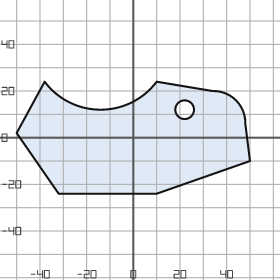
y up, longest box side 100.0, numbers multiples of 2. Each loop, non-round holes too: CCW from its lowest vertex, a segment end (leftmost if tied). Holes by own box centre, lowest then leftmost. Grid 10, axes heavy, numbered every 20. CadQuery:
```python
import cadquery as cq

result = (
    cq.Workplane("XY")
    .moveTo(-32.0, -24.0)
    .lineTo(10.0, -24.0)
    .lineTo(50.0, -10.0)
    .lineTo(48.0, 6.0)
    .threePointArc((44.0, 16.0), (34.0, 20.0))
    .lineTo(10.0, 24.0)
    .threePointArc((-14.0, 12.0), (-38.0, 24.0))
    .lineTo(-50.0, 2.0)
    .close()
    .moveTo(22.0, 12.0)
    .circle(4.0)
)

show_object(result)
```